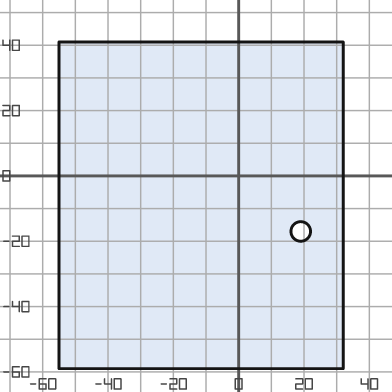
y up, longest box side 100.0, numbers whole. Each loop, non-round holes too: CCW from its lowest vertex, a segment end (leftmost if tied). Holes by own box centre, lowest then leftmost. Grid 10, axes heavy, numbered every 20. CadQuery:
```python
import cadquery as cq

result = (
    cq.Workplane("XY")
    .moveTo(-55.0, -59.0)
    .lineTo(32.0, -59.0)
    .lineTo(32.0, 41.0)
    .lineTo(-55.0, 41.0)
    .close()
    .moveTo(19.0, -17.0)
    .circle(3.0)
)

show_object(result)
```